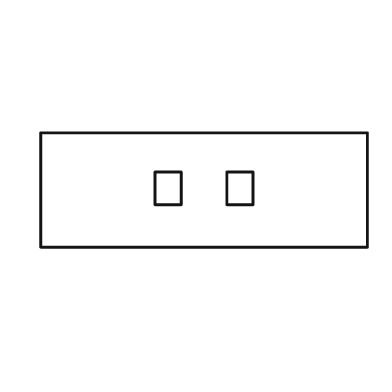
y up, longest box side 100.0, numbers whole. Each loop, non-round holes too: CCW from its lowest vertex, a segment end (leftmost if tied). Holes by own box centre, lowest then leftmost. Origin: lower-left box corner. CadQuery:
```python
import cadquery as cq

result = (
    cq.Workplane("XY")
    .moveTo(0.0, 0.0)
    .lineTo(100.0, 0.0)
    .lineTo(100.0, 35.0)
    .lineTo(0.0, 35.0)
    .close()
    .moveTo(35.0, 13.0)
    .lineTo(43.0, 13.0)
    .lineTo(43.0, 23.0)
    .lineTo(35.0, 23.0)
    .close()
    .moveTo(57.0, 13.0)
    .lineTo(65.0, 13.0)
    .lineTo(65.0, 23.0)
    .lineTo(57.0, 23.0)
    .close()
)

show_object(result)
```